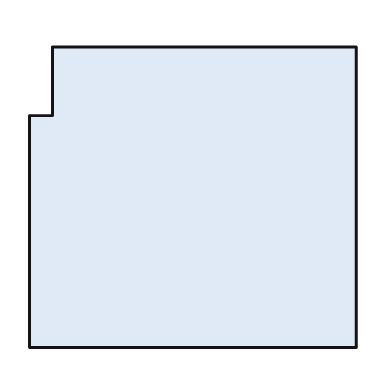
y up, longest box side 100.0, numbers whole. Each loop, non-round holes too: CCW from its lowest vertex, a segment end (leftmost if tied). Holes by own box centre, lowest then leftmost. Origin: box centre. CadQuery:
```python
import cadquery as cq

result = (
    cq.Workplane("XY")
    .moveTo(-50.0, -46.0)
    .lineTo(50.0, -46.0)
    .lineTo(50.0, 46.0)
    .lineTo(-43.0, 46.0)
    .lineTo(-43.0, 25.0)
    .lineTo(-50.0, 25.0)
    .close()
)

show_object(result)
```